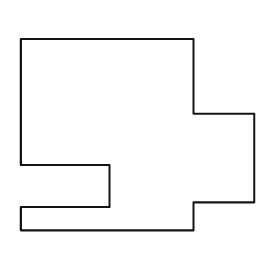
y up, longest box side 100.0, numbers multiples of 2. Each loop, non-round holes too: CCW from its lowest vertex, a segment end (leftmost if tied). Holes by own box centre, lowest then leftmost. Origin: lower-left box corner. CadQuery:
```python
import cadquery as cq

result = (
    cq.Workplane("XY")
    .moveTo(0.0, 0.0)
    .lineTo(74.0, 0.0)
    .lineTo(74.0, 12.0)
    .lineTo(100.0, 12.0)
    .lineTo(100.0, 50.0)
    .lineTo(74.0, 50.0)
    .lineTo(74.0, 82.0)
    .lineTo(0.0, 82.0)
    .lineTo(0.0, 28.0)
    .lineTo(38.0, 28.0)
    .lineTo(38.0, 10.0)
    .lineTo(0.0, 10.0)
    .close()
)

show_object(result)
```